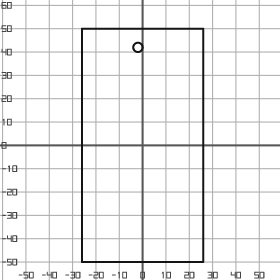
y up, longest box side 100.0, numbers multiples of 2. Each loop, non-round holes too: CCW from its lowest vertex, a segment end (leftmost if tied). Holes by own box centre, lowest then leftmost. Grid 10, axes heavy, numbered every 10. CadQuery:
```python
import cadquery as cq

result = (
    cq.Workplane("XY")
    .moveTo(-26.0, -50.0)
    .lineTo(26.0, -50.0)
    .lineTo(26.0, 50.0)
    .lineTo(-26.0, 50.0)
    .close()
    .moveTo(-2.0, 42.0)
    .circle(2.0)
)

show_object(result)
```